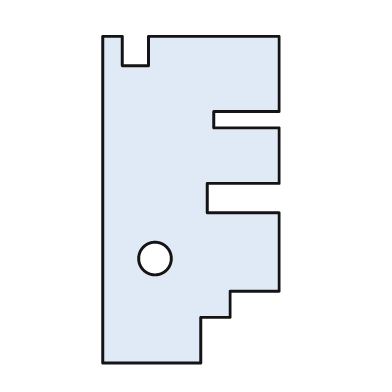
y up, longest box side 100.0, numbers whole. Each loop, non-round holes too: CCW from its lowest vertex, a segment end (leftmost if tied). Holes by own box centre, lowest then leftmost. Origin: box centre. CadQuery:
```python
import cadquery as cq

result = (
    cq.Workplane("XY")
    .moveTo(-27.0, -50.0)
    .lineTo(3.0, -50.0)
    .lineTo(3.0, -36.0)
    .lineTo(12.0, -36.0)
    .lineTo(12.0, -28.0)
    .lineTo(27.0, -28.0)
    .lineTo(27.0, -4.0)
    .lineTo(5.0, -4.0)
    .lineTo(5.0, 5.0)
    .lineTo(27.0, 5.0)
    .lineTo(27.0, 22.0)
    .lineTo(7.0, 22.0)
    .lineTo(7.0, 27.0)
    .lineTo(27.0, 27.0)
    .lineTo(27.0, 50.0)
    .lineTo(-13.0, 50.0)
    .lineTo(-13.0, 41.0)
    .lineTo(-21.0, 41.0)
    .lineTo(-21.0, 50.0)
    .lineTo(-27.0, 50.0)
    .close()
    .moveTo(-11.0, -18.0)
    .circle(5.0)
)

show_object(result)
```